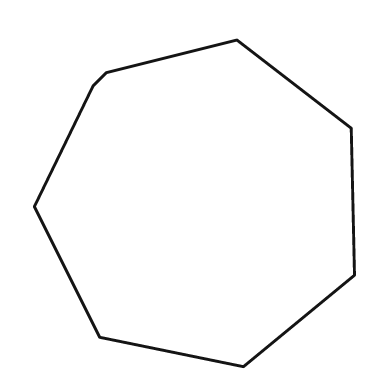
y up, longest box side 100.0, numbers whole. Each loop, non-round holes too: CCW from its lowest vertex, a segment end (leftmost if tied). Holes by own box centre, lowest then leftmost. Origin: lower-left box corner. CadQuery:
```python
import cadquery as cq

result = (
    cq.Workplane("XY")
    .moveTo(64.0, 0.0)
    .lineTo(98.0, 28.0)
    .lineTo(97.0, 73.0)
    .lineTo(62.0, 100.0)
    .lineTo(22.0, 90.0)
    .lineTo(18.0, 86.0)
    .lineTo(0.0, 49.0)
    .lineTo(20.0, 9.0)
    .close()
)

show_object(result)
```